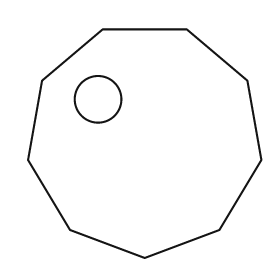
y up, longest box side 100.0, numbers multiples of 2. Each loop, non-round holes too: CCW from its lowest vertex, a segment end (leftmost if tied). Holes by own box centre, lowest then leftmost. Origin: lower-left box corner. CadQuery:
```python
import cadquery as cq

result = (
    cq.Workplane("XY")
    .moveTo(50.0, 0.0)
    .lineTo(82.0, 12.0)
    .lineTo(100.0, 42.0)
    .lineTo(94.0, 76.0)
    .lineTo(68.0, 98.0)
    .lineTo(32.0, 98.0)
    .lineTo(6.0, 76.0)
    .lineTo(0.0, 42.0)
    .lineTo(18.0, 12.0)
    .close()
    .moveTo(30.0, 68.0)
    .circle(10.0)
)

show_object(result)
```